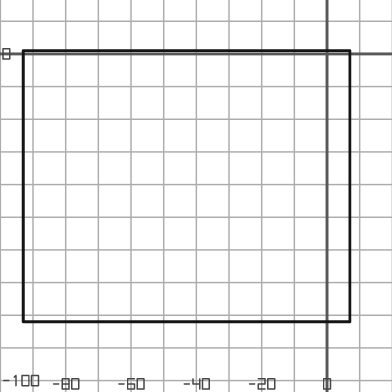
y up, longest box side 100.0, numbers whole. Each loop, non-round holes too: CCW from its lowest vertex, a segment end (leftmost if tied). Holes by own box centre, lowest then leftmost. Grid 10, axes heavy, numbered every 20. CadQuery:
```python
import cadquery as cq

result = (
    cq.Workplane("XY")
    .moveTo(-93.0, -82.0)
    .lineTo(7.0, -82.0)
    .lineTo(7.0, 1.0)
    .lineTo(-93.0, 1.0)
    .close()
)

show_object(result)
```